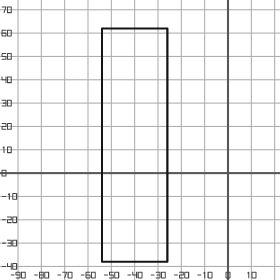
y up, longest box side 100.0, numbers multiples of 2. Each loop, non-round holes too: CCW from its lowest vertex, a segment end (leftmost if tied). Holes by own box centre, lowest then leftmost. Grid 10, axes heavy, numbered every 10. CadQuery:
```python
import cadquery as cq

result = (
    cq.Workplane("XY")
    .moveTo(-54.0, -38.0)
    .lineTo(-26.0, -38.0)
    .lineTo(-26.0, 62.0)
    .lineTo(-54.0, 62.0)
    .close()
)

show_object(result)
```